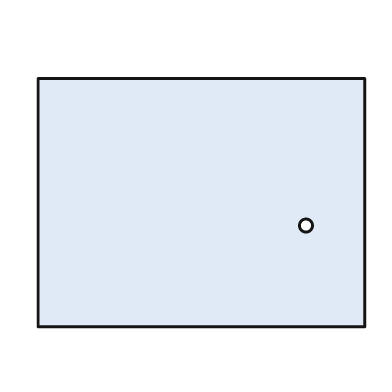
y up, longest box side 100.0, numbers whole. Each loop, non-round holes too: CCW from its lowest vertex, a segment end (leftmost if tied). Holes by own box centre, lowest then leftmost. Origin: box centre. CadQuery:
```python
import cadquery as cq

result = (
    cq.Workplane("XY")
    .moveTo(-50.0, -38.0)
    .lineTo(50.0, -38.0)
    .lineTo(50.0, 38.0)
    .lineTo(-50.0, 38.0)
    .close()
    .moveTo(32.0, -7.0)
    .circle(2.0)
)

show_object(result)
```